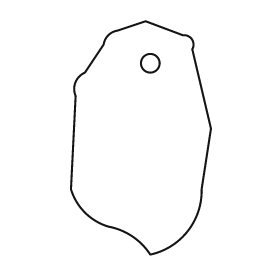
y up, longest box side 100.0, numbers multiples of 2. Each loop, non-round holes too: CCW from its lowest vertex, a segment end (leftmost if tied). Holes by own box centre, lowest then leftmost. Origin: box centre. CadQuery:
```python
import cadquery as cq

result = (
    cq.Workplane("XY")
    .moveTo(4.0, -50.0)
    .threePointArc((20.0, -40.0), (26.0, -22.0))
    .lineTo(30.0, 4.0)
    .lineTo(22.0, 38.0)
    .threePointArc((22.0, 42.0), (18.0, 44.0))
    .lineTo(2.0, 50.0)
    .lineTo(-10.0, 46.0)
    .threePointArc((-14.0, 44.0), (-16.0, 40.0))
    .lineTo(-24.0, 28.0)
    .threePointArc((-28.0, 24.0), (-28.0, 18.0))
    .lineTo(-30.0, -22.0)
    .threePointArc((-24.0, -32.0), (-14.0, -38.0))
    .threePointArc((-4.0, -42.0), (4.0, -50.0))
    .close()
    .moveTo(4.0, 32.0)
    .circle(4.0)
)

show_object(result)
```